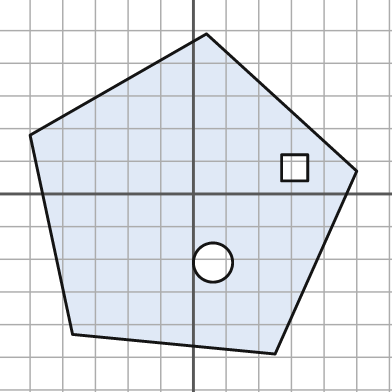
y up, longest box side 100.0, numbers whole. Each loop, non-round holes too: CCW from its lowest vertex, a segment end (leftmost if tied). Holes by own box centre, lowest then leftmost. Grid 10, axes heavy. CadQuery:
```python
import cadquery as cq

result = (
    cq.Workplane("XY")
    .moveTo(25.0, -49.0)
    .lineTo(50.0, 7.0)
    .lineTo(4.0, 49.0)
    .lineTo(-50.0, 18.0)
    .lineTo(-37.0, -43.0)
    .close()
    .moveTo(6.0, -21.0)
    .circle(6.0)
    .moveTo(27.0, 4.0)
    .lineTo(35.0, 4.0)
    .lineTo(35.0, 12.0)
    .lineTo(27.0, 12.0)
    .close()
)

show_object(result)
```